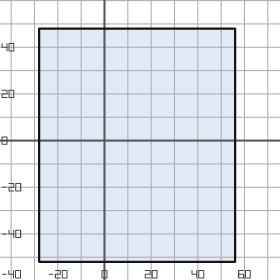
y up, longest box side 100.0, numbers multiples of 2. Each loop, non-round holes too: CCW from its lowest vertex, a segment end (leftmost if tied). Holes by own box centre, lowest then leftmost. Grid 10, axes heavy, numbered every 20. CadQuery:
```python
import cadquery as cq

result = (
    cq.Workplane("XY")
    .moveTo(-28.0, -52.0)
    .lineTo(56.0, -52.0)
    .lineTo(56.0, 48.0)
    .lineTo(-28.0, 48.0)
    .close()
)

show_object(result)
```